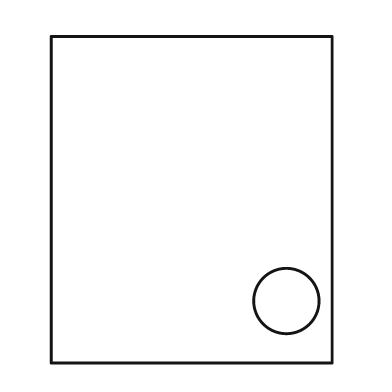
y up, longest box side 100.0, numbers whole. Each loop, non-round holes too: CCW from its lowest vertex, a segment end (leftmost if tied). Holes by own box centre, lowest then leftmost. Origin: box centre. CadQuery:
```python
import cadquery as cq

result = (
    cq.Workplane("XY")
    .moveTo(-43.0, -50.0)
    .lineTo(43.0, -50.0)
    .lineTo(43.0, 50.0)
    .lineTo(-43.0, 50.0)
    .close()
    .moveTo(29.0, -31.0)
    .circle(10.0)
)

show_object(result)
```